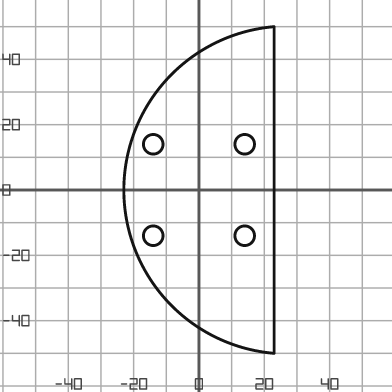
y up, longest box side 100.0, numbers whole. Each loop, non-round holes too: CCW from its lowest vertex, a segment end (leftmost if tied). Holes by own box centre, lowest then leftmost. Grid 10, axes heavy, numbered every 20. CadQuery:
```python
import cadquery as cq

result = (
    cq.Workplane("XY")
    .moveTo(23.0, -50.0)
    .lineTo(23.0, 50.0)
    .threePointArc((-23.0, 0.0), (23.0, -50.0))
    .close()
    .moveTo(-14.0, -14.0)
    .circle(3.0)
    .moveTo(14.0, -14.0)
    .circle(3.0)
    .moveTo(-14.0, 14.0)
    .circle(3.0)
    .moveTo(14.0, 14.0)
    .circle(3.0)
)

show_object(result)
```